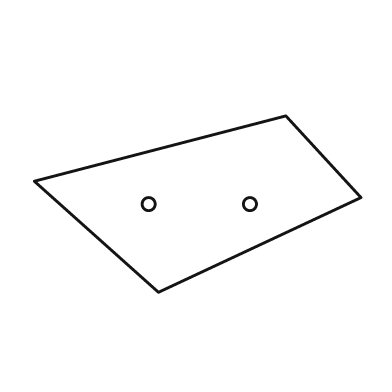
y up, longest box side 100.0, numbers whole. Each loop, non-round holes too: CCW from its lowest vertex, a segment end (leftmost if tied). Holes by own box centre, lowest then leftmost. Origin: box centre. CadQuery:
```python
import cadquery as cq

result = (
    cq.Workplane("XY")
    .moveTo(-12.0, -27.0)
    .lineTo(50.0, 2.0)
    .lineTo(27.0, 27.0)
    .lineTo(-50.0, 7.0)
    .close()
    .moveTo(-15.0, 0.0)
    .circle(2.0)
    .moveTo(16.0, 0.0)
    .circle(2.0)
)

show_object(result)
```